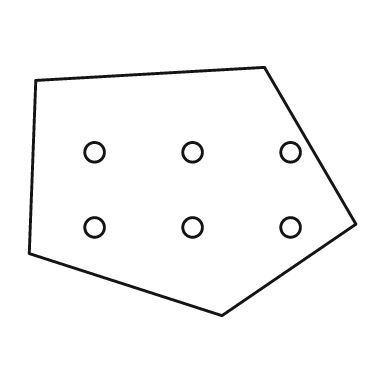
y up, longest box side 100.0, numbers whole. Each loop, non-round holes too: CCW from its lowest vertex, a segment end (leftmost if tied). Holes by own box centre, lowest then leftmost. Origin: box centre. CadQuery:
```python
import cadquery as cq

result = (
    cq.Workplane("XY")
    .moveTo(9.0, -38.0)
    .lineTo(50.0, -10.0)
    .lineTo(22.0, 38.0)
    .lineTo(-48.0, 34.0)
    .lineTo(-50.0, -19.0)
    .close()
    .moveTo(-30.0, -11.0)
    .circle(3.0)
    .moveTo(0.0, -11.0)
    .circle(3.0)
    .moveTo(30.0, -11.0)
    .circle(3.0)
    .moveTo(-30.0, 12.0)
    .circle(3.0)
    .moveTo(0.0, 12.0)
    .circle(3.0)
    .moveTo(30.0, 12.0)
    .circle(3.0)
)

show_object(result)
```